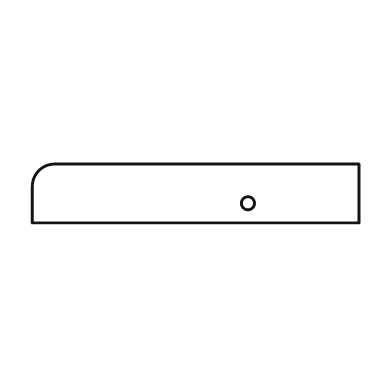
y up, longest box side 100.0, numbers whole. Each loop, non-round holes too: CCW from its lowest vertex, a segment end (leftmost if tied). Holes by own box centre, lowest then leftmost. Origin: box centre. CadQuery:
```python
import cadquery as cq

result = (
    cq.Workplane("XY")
    .moveTo(-50.0, -9.0)
    .lineTo(50.0, -9.0)
    .lineTo(50.0, 9.0)
    .lineTo(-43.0, 9.0)
    .threePointArc((-48.0, 7.0), (-50.0, 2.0))
    .close()
    .moveTo(16.0, -3.0)
    .circle(2.0)
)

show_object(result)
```